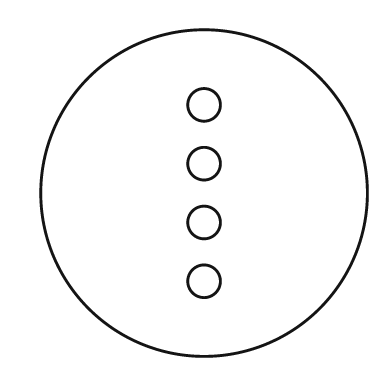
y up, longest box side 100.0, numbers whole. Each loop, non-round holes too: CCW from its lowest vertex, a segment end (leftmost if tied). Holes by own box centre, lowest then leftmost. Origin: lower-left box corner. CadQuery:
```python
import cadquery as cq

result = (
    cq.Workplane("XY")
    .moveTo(50.0, 50.0)
    .circle(50.0)
    .moveTo(50.0, 23.0)
    .circle(5.0)
    .moveTo(50.0, 41.0)
    .circle(5.0)
    .moveTo(50.0, 59.0)
    .circle(5.0)
    .moveTo(50.0, 77.0)
    .circle(5.0)
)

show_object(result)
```